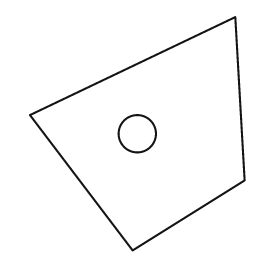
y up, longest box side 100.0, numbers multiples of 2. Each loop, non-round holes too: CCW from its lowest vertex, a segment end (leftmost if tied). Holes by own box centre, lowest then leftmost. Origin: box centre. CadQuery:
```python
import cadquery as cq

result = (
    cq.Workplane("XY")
    .moveTo(-2.0, -50.0)
    .lineTo(46.0, -20.0)
    .lineTo(42.0, 50.0)
    .lineTo(-46.0, 8.0)
    .close()
    .moveTo(0.0, 0.0)
    .circle(8.0)
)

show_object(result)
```